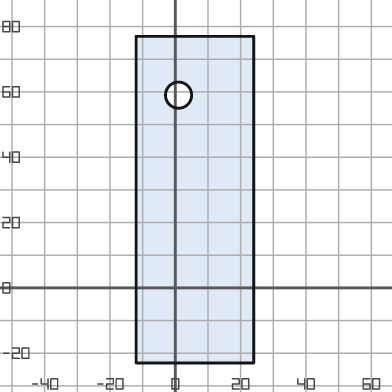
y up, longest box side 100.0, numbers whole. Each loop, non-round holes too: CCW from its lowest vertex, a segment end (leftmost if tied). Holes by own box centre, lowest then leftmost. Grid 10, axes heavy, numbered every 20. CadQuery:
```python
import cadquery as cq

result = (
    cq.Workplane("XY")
    .moveTo(-12.0, -23.0)
    .lineTo(24.0, -23.0)
    .lineTo(24.0, 77.0)
    .lineTo(-12.0, 77.0)
    .close()
    .moveTo(1.0, 59.0)
    .circle(4.0)
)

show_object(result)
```